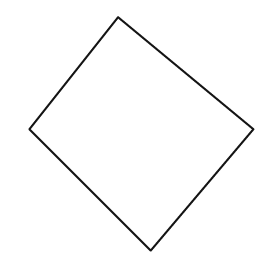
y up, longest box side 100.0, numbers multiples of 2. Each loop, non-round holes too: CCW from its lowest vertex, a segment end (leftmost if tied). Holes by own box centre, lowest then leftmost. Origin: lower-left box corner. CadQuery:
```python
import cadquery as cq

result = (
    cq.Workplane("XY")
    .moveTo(52.0, 0.0)
    .lineTo(96.0, 52.0)
    .lineTo(38.0, 100.0)
    .lineTo(0.0, 52.0)
    .close()
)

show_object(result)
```